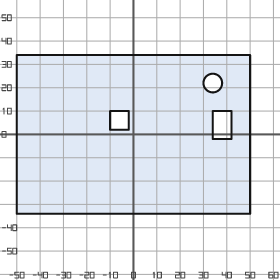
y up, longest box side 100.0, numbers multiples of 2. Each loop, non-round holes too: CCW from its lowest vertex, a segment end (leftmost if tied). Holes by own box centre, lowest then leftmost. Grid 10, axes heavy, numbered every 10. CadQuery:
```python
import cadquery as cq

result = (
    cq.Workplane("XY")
    .moveTo(-50.0, -34.0)
    .lineTo(50.0, -34.0)
    .lineTo(50.0, 34.0)
    .lineTo(-50.0, 34.0)
    .close()
    .moveTo(34.0, -2.0)
    .lineTo(42.0, -2.0)
    .lineTo(42.0, 10.0)
    .lineTo(34.0, 10.0)
    .close()
    .moveTo(-10.0, 2.0)
    .lineTo(-2.0, 2.0)
    .lineTo(-2.0, 10.0)
    .lineTo(-10.0, 10.0)
    .close()
    .moveTo(34.0, 22.0)
    .circle(4.0)
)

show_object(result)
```